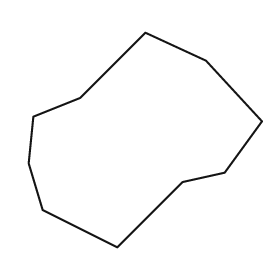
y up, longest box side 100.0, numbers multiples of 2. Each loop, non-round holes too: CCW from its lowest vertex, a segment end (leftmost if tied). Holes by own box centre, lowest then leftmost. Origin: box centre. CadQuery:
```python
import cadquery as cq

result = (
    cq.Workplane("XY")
    .moveTo(-12.0, -46.0)
    .lineTo(16.0, -18.0)
    .lineTo(34.0, -14.0)
    .lineTo(50.0, 8.0)
    .lineTo(26.0, 34.0)
    .lineTo(0.0, 46.0)
    .lineTo(-28.0, 18.0)
    .lineTo(-48.0, 10.0)
    .lineTo(-50.0, -10.0)
    .lineTo(-44.0, -30.0)
    .close()
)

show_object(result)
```